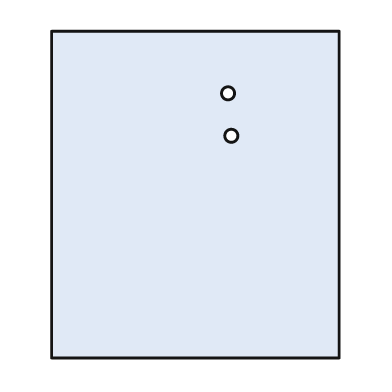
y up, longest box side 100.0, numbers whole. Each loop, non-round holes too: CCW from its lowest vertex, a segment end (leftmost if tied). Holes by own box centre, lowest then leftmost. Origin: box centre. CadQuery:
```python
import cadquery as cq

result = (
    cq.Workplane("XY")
    .moveTo(-44.0, -50.0)
    .lineTo(44.0, -50.0)
    .lineTo(44.0, 50.0)
    .lineTo(-44.0, 50.0)
    .close()
    .moveTo(11.0, 18.0)
    .circle(2.0)
    .moveTo(10.0, 31.0)
    .circle(2.0)
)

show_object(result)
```